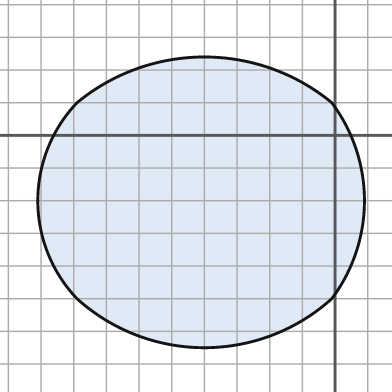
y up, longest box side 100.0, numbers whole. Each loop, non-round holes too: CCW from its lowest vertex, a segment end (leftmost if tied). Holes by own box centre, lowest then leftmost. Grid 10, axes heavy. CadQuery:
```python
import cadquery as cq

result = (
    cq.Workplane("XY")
    .moveTo(-79.0, -50.0)
    .threePointArc((-40.0, -65.0), (-1.0, -50.0))
    .threePointArc((9.0, -20.0), (-1.0, 10.0))
    .threePointArc((-40.0, 24.0), (-79.0, 10.0))
    .threePointArc((-91.0, -20.0), (-79.0, -50.0))
    .close()
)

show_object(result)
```